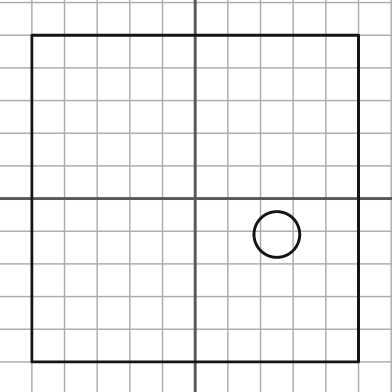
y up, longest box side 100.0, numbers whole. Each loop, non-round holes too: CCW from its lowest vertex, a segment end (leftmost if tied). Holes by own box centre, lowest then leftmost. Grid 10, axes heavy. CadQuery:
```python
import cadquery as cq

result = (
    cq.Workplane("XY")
    .moveTo(-50.0, -50.0)
    .lineTo(50.0, -50.0)
    .lineTo(50.0, 50.0)
    .lineTo(-50.0, 50.0)
    .close()
    .moveTo(25.0, -11.0)
    .circle(7.0)
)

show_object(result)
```